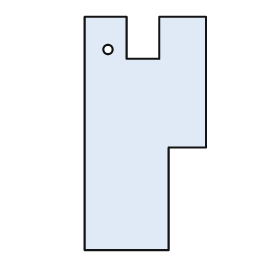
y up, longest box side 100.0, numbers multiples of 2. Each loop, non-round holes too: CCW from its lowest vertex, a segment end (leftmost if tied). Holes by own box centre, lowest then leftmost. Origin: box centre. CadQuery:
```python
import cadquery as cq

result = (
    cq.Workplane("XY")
    .moveTo(-26.0, -50.0)
    .lineTo(10.0, -50.0)
    .lineTo(10.0, -6.0)
    .lineTo(26.0, -6.0)
    .lineTo(26.0, 50.0)
    .lineTo(6.0, 50.0)
    .lineTo(6.0, 32.0)
    .lineTo(-8.0, 32.0)
    .lineTo(-8.0, 50.0)
    .lineTo(-26.0, 50.0)
    .close()
    .moveTo(-16.0, 36.0)
    .circle(2.0)
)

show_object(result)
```